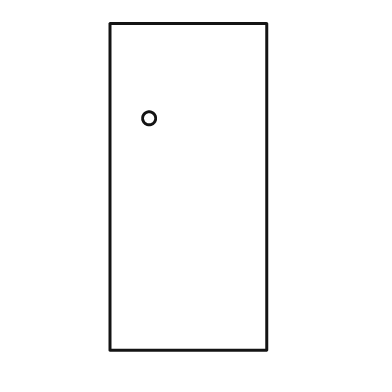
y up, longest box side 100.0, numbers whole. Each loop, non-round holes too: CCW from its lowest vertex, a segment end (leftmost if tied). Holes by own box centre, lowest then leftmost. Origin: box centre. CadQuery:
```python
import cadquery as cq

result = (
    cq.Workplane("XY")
    .moveTo(-24.0, -50.0)
    .lineTo(24.0, -50.0)
    .lineTo(24.0, 50.0)
    .lineTo(-24.0, 50.0)
    .close()
    .moveTo(-12.0, 21.0)
    .circle(2.0)
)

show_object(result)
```